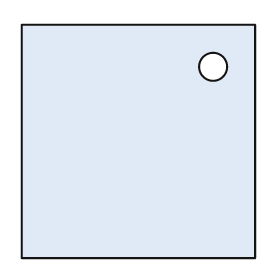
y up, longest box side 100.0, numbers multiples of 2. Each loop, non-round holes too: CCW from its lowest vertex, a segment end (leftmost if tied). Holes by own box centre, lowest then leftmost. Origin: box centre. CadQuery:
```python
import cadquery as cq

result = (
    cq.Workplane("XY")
    .moveTo(-50.0, -50.0)
    .lineTo(50.0, -50.0)
    .lineTo(50.0, 50.0)
    .lineTo(-50.0, 50.0)
    .close()
    .moveTo(32.0, 32.0)
    .circle(6.0)
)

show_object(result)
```